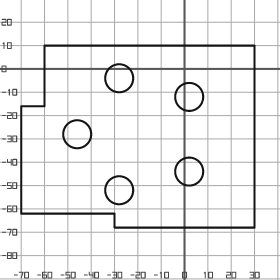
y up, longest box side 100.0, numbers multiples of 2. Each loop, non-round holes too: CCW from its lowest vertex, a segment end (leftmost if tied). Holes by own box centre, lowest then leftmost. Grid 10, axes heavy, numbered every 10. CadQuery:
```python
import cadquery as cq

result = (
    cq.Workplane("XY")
    .moveTo(-30.0, -68.0)
    .lineTo(30.0, -68.0)
    .lineTo(30.0, 10.0)
    .lineTo(-60.0, 10.0)
    .lineTo(-60.0, -16.0)
    .lineTo(-70.0, -16.0)
    .lineTo(-70.0, -62.0)
    .lineTo(-30.0, -62.0)
    .close()
    .moveTo(-28.0, -52.0)
    .circle(6.0)
    .moveTo(2.0, -44.0)
    .circle(6.0)
    .moveTo(-46.0, -28.0)
    .circle(6.0)
    .moveTo(2.0, -12.0)
    .circle(6.0)
    .moveTo(-28.0, -4.0)
    .circle(6.0)
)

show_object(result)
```